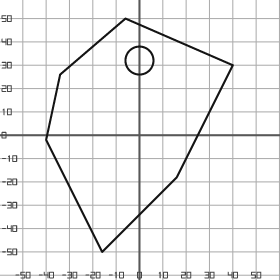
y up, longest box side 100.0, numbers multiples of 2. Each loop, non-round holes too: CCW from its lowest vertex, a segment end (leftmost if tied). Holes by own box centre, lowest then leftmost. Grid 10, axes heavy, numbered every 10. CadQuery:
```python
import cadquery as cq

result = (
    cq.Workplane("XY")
    .moveTo(-16.0, -50.0)
    .lineTo(16.0, -18.0)
    .lineTo(40.0, 30.0)
    .lineTo(-6.0, 50.0)
    .lineTo(-34.0, 26.0)
    .lineTo(-40.0, -2.0)
    .close()
    .moveTo(0.0, 32.0)
    .circle(6.0)
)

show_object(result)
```